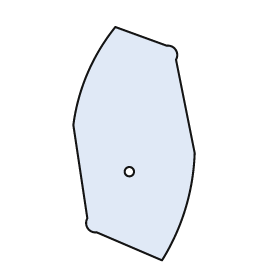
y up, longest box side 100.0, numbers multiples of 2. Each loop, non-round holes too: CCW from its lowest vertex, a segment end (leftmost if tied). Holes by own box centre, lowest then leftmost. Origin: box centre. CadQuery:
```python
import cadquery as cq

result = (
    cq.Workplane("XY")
    .moveTo(12.0, -50.0)
    .threePointArc((22.0, -28.0), (26.0, -4.0))
    .lineTo(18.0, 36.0)
    .threePointArc((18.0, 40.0), (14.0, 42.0))
    .lineTo(-8.0, 50.0)
    .threePointArc((-20.0, 30.0), (-26.0, 8.0))
    .lineTo(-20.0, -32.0)
    .threePointArc((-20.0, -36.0), (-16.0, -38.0))
    .close()
    .moveTo(-2.0, -12.0)
    .circle(2.0)
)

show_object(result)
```